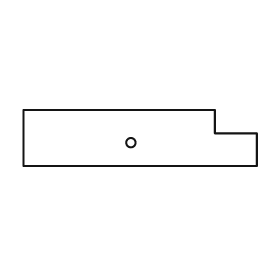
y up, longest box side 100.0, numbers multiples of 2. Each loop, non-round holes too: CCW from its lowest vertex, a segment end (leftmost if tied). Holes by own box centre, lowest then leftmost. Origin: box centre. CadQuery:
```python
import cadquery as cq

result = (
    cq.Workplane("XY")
    .moveTo(-50.0, -12.0)
    .lineTo(50.0, -12.0)
    .lineTo(50.0, 2.0)
    .lineTo(32.0, 2.0)
    .lineTo(32.0, 12.0)
    .lineTo(-50.0, 12.0)
    .close()
    .moveTo(-4.0, -2.0)
    .circle(2.0)
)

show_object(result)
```